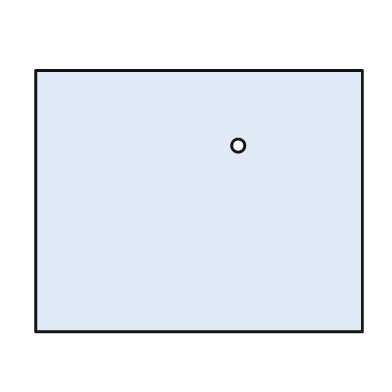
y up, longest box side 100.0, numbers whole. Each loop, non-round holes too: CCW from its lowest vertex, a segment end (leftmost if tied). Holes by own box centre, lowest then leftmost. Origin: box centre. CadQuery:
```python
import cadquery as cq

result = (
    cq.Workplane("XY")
    .moveTo(-50.0, -40.0)
    .lineTo(50.0, -40.0)
    .lineTo(50.0, 40.0)
    .lineTo(-50.0, 40.0)
    .close()
    .moveTo(12.0, 17.0)
    .circle(2.0)
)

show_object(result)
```